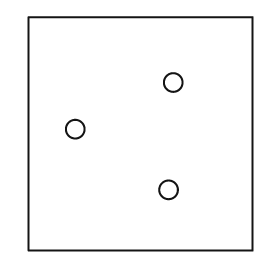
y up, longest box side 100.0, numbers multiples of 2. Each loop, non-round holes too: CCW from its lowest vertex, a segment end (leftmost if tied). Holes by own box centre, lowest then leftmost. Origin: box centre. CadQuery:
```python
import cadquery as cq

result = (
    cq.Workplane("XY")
    .moveTo(-48.0, -50.0)
    .lineTo(48.0, -50.0)
    .lineTo(48.0, 50.0)
    .lineTo(-48.0, 50.0)
    .close()
    .moveTo(12.0, -24.0)
    .circle(4.0)
    .moveTo(-28.0, 2.0)
    .circle(4.0)
    .moveTo(14.0, 22.0)
    .circle(4.0)
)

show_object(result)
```